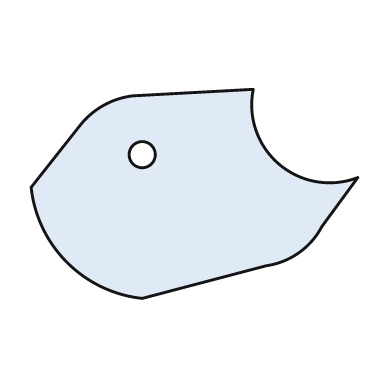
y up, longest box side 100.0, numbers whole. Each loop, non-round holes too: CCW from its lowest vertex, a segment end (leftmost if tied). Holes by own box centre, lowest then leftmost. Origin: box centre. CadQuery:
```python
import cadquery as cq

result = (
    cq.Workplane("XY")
    .moveTo(-16.0, -32.0)
    .lineTo(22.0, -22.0)
    .threePointArc((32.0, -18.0), (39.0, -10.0))
    .lineTo(50.0, 5.0)
    .threePointArc((26.0, 9.0), (18.0, 32.0))
    .lineTo(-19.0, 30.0)
    .threePointArc((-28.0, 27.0), (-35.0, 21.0))
    .lineTo(-50.0, 2.0)
    .threePointArc((-39.0, -21.0), (-16.0, -32.0))
    .close()
    .moveTo(-16.0, 12.0)
    .circle(4.0)
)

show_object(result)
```